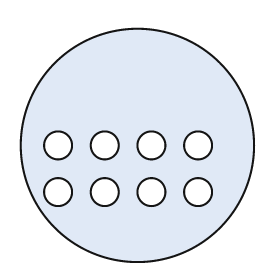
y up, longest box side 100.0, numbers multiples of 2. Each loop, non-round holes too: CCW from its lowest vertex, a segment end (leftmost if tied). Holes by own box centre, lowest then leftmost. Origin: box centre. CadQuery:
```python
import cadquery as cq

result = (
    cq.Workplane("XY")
    .moveTo(0.0, 0.0)
    .circle(50.0)
    .moveTo(-34.0, -20.0)
    .circle(6.0)
    .moveTo(-14.0, -20.0)
    .circle(6.0)
    .moveTo(6.0, -20.0)
    .circle(6.0)
    .moveTo(26.0, -20.0)
    .circle(6.0)
    .moveTo(-34.0, 0.0)
    .circle(6.0)
    .moveTo(-14.0, 0.0)
    .circle(6.0)
    .moveTo(6.0, 0.0)
    .circle(6.0)
    .moveTo(26.0, 0.0)
    .circle(6.0)
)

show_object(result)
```